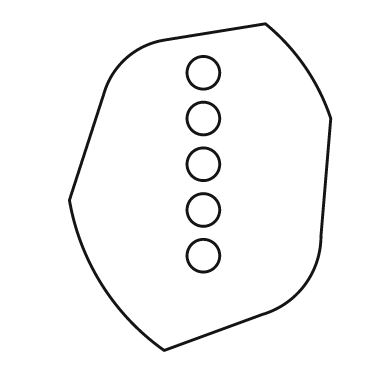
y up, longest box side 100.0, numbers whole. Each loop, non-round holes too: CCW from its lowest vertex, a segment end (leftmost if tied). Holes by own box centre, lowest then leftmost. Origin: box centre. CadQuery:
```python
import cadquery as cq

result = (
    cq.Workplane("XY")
    .moveTo(-11.0, -50.0)
    .lineTo(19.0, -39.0)
    .threePointArc((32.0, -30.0), (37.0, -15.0))
    .lineTo(40.0, 21.0)
    .threePointArc((32.0, 37.0), (20.0, 50.0))
    .lineTo(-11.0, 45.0)
    .threePointArc((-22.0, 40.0), (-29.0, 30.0))
    .lineTo(-40.0, -4.0)
    .threePointArc((-30.0, -30.0), (-11.0, -50.0))
    .close()
    .moveTo(1.0, -21.0)
    .circle(5.0)
    .moveTo(1.0, -7.0)
    .circle(5.0)
    .moveTo(1.0, 7.0)
    .circle(5.0)
    .moveTo(1.0, 21.0)
    .circle(5.0)
    .moveTo(1.0, 35.0)
    .circle(5.0)
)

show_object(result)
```